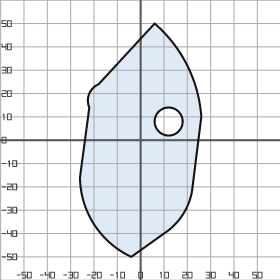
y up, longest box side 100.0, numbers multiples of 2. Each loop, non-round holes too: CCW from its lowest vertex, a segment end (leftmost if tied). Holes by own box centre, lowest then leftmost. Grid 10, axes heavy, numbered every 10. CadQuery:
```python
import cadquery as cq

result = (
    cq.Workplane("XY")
    .moveTo(-4.0, -50.0)
    .lineTo(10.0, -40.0)
    .threePointArc((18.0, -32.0), (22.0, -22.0))
    .lineTo(26.0, 10.0)
    .threePointArc((20.0, 32.0), (6.0, 50.0))
    .lineTo(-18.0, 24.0)
    .threePointArc((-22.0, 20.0), (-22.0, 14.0))
    .lineTo(-26.0, -16.0)
    .threePointArc((-20.0, -36.0), (-4.0, -50.0))
    .close()
    .moveTo(12.0, 8.0)
    .circle(6.0)
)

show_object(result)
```